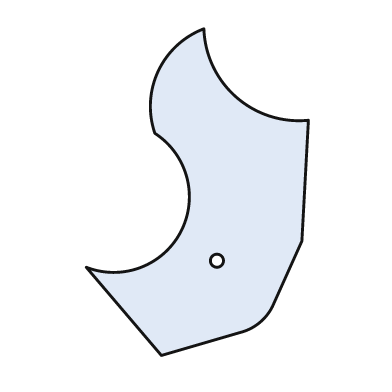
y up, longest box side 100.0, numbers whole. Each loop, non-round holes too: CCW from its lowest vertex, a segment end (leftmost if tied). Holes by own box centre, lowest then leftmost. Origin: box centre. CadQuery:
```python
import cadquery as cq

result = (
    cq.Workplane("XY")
    .moveTo(-11.0, -50.0)
    .lineTo(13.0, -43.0)
    .threePointArc((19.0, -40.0), (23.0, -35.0))
    .lineTo(32.0, -15.0)
    .lineTo(34.0, 22.0)
    .threePointArc((12.0, 29.0), (2.0, 50.0))
    .threePointArc((-12.0, 37.0), (-13.0, 18.0))
    .threePointArc((-5.0, -12.0), (-34.0, -23.0))
    .close()
    .moveTo(6.0, -21.0)
    .circle(2.0)
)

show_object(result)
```